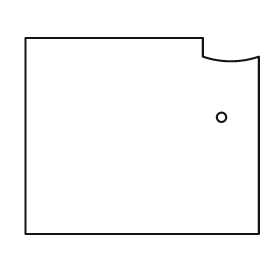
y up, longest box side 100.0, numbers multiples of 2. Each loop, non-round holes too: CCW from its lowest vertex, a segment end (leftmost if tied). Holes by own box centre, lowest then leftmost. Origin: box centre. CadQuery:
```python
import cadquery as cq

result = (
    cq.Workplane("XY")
    .moveTo(-50.0, -42.0)
    .lineTo(50.0, -42.0)
    .lineTo(50.0, 34.0)
    .threePointArc((38.0, 32.0), (26.0, 34.0))
    .lineTo(26.0, 42.0)
    .lineTo(-50.0, 42.0)
    .close()
    .moveTo(34.0, 8.0)
    .circle(2.0)
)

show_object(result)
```